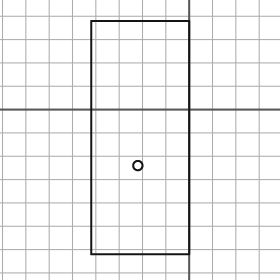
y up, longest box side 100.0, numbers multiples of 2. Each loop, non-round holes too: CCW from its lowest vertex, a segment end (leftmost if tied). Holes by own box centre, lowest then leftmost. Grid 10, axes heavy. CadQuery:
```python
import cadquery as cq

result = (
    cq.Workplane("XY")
    .moveTo(-42.0, -62.0)
    .lineTo(0.0, -62.0)
    .lineTo(0.0, 38.0)
    .lineTo(-42.0, 38.0)
    .close()
    .moveTo(-22.0, -24.0)
    .circle(2.0)
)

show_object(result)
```